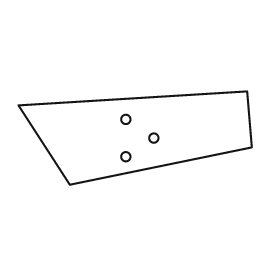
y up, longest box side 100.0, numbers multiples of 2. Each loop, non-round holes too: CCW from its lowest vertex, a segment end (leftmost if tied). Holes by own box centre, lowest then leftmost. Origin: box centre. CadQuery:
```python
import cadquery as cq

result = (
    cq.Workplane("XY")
    .moveTo(-28.0, -20.0)
    .lineTo(50.0, -4.0)
    .lineTo(48.0, 20.0)
    .lineTo(-50.0, 14.0)
    .close()
    .moveTo(-4.0, -8.0)
    .circle(2.0)
    .moveTo(8.0, 0.0)
    .circle(2.0)
    .moveTo(-4.0, 8.0)
    .circle(2.0)
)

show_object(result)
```